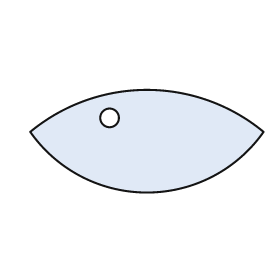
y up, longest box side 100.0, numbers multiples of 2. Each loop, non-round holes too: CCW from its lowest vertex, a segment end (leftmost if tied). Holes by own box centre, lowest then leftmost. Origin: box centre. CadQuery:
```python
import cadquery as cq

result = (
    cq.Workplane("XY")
    .moveTo(-50.0, 4.0)
    .threePointArc((0.0, -22.0), (50.0, 4.0))
    .threePointArc((0.0, 22.0), (-50.0, 4.0))
    .close()
    .moveTo(-16.0, 10.0)
    .circle(4.0)
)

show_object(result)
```